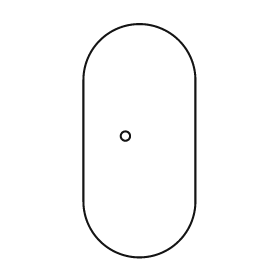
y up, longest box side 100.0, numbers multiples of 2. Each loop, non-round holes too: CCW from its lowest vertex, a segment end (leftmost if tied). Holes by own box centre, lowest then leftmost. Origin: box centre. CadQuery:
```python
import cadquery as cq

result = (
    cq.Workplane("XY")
    .moveTo(-24.0, -26.0)
    .threePointArc((0.0, -50.0), (24.0, -26.0))
    .lineTo(24.0, 26.0)
    .threePointArc((0.0, 50.0), (-24.0, 26.0))
    .close()
    .moveTo(-6.0, 2.0)
    .circle(2.0)
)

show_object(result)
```